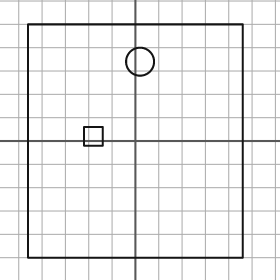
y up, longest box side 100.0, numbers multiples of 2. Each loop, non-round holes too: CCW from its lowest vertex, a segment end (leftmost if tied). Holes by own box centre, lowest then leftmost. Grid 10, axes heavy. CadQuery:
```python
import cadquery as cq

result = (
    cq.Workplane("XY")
    .moveTo(-46.0, -50.0)
    .lineTo(46.0, -50.0)
    .lineTo(46.0, 50.0)
    .lineTo(-46.0, 50.0)
    .close()
    .moveTo(-22.0, -2.0)
    .lineTo(-14.0, -2.0)
    .lineTo(-14.0, 6.0)
    .lineTo(-22.0, 6.0)
    .close()
    .moveTo(2.0, 34.0)
    .circle(6.0)
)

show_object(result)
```